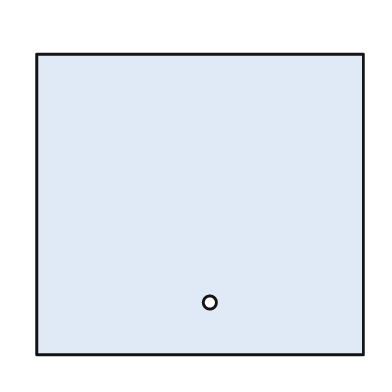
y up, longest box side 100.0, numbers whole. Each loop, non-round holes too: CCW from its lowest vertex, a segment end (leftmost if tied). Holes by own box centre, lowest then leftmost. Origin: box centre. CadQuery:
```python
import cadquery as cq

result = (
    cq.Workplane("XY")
    .moveTo(-50.0, -46.0)
    .lineTo(50.0, -46.0)
    .lineTo(50.0, 46.0)
    .lineTo(-50.0, 46.0)
    .close()
    .moveTo(3.0, -30.0)
    .circle(2.0)
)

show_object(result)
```